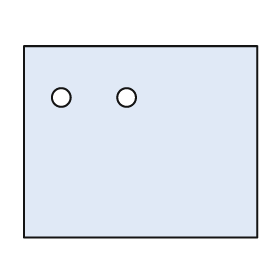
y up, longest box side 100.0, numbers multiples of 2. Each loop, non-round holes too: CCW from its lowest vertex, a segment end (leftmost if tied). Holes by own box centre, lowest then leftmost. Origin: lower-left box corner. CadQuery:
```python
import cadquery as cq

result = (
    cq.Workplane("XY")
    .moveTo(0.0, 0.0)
    .lineTo(100.0, 0.0)
    .lineTo(100.0, 82.0)
    .lineTo(0.0, 82.0)
    .close()
    .moveTo(16.0, 60.0)
    .circle(4.0)
    .moveTo(44.0, 60.0)
    .circle(4.0)
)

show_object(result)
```